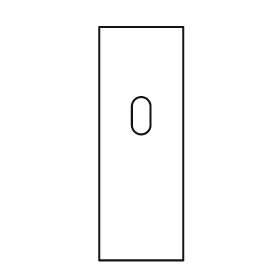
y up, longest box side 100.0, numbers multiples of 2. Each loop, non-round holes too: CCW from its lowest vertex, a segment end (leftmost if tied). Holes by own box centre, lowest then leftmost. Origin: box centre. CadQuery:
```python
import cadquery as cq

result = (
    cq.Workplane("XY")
    .moveTo(-18.0, -50.0)
    .lineTo(18.0, -50.0)
    .lineTo(18.0, 50.0)
    .lineTo(-18.0, 50.0)
    .close()
    .moveTo(-4.0, 8.0)
    .threePointArc((0.0, 4.0), (4.0, 8.0))
    .lineTo(4.0, 16.0)
    .threePointArc((0.0, 20.0), (-4.0, 16.0))
    .close()
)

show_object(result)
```